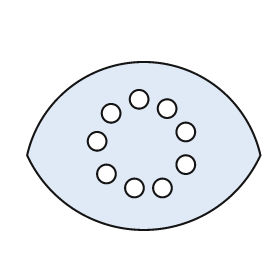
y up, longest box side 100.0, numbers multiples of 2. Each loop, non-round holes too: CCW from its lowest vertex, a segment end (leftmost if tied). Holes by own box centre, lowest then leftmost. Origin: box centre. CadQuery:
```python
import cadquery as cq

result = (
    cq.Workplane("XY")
    .moveTo(-50.0, -4.0)
    .threePointArc((0.0, -36.0), (50.0, -4.0))
    .threePointArc((0.0, 36.0), (-50.0, -4.0))
    .close()
    .moveTo(-4.0, -18.0)
    .circle(4.0)
    .moveTo(8.0, -18.0)
    .circle(4.0)
    .moveTo(-16.0, -12.0)
    .circle(4.0)
    .moveTo(18.0, -8.0)
    .circle(4.0)
    .moveTo(-20.0, 2.0)
    .circle(4.0)
    .moveTo(18.0, 6.0)
    .circle(4.0)
    .moveTo(-14.0, 14.0)
    .circle(4.0)
    .moveTo(10.0, 16.0)
    .circle(4.0)
    .moveTo(-2.0, 20.0)
    .circle(4.0)
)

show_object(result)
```